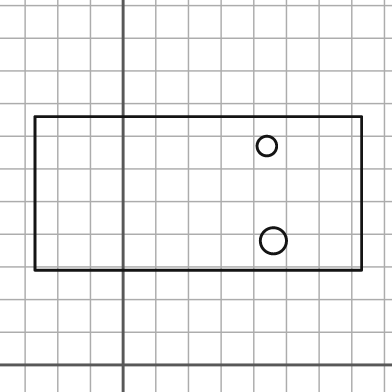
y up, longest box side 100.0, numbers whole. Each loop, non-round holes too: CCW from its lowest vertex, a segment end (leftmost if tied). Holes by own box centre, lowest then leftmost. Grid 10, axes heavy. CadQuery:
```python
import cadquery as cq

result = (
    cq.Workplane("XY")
    .moveTo(-27.0, 29.0)
    .lineTo(73.0, 29.0)
    .lineTo(73.0, 76.0)
    .lineTo(-27.0, 76.0)
    .close()
    .moveTo(46.0, 38.0)
    .circle(4.0)
    .moveTo(44.0, 67.0)
    .circle(3.0)
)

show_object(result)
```